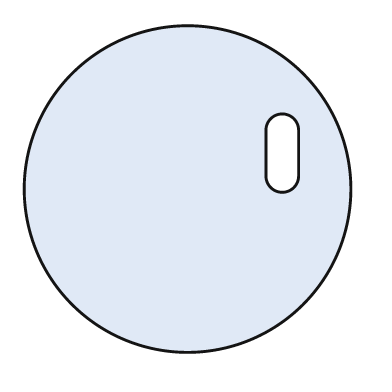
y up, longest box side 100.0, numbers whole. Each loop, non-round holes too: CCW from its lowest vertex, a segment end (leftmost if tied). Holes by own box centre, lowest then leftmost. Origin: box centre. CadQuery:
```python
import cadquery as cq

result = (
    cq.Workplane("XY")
    .moveTo(0.0, 0.0)
    .circle(50.0)
    .moveTo(24.0, 4.0)
    .threePointArc((29.0, -1.0), (34.0, 4.0))
    .lineTo(34.0, 18.0)
    .threePointArc((29.0, 23.0), (24.0, 18.0))
    .close()
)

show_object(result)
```